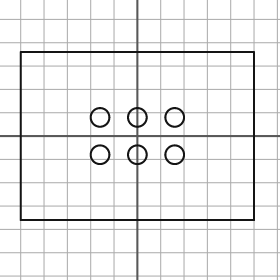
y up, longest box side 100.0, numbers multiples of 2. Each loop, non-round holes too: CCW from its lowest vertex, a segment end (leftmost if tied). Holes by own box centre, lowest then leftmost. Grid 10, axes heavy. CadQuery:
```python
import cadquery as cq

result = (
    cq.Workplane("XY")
    .moveTo(-50.0, -36.0)
    .lineTo(50.0, -36.0)
    .lineTo(50.0, 36.0)
    .lineTo(-50.0, 36.0)
    .close()
    .moveTo(-16.0, -8.0)
    .circle(4.0)
    .moveTo(0.0, -8.0)
    .circle(4.0)
    .moveTo(16.0, -8.0)
    .circle(4.0)
    .moveTo(-16.0, 8.0)
    .circle(4.0)
    .moveTo(0.0, 8.0)
    .circle(4.0)
    .moveTo(16.0, 8.0)
    .circle(4.0)
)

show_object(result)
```